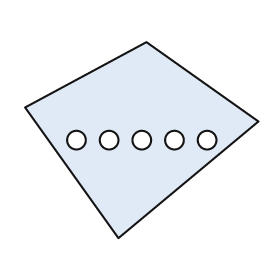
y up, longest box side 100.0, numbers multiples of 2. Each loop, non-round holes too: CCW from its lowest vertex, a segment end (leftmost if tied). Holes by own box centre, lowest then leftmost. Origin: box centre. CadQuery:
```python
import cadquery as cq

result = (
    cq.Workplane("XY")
    .moveTo(-10.0, -42.0)
    .lineTo(50.0, 8.0)
    .lineTo(2.0, 42.0)
    .lineTo(-50.0, 14.0)
    .close()
    .moveTo(-28.0, 0.0)
    .circle(4.0)
    .moveTo(-14.0, 0.0)
    .circle(4.0)
    .moveTo(0.0, 0.0)
    .circle(4.0)
    .moveTo(14.0, 0.0)
    .circle(4.0)
    .moveTo(28.0, 0.0)
    .circle(4.0)
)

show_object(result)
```